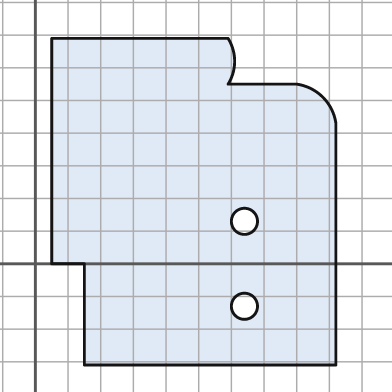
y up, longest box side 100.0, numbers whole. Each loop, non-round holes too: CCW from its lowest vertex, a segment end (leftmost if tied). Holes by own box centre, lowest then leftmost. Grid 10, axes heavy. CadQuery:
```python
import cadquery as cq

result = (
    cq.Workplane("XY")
    .moveTo(15.0, -31.0)
    .lineTo(92.0, -31.0)
    .lineTo(92.0, 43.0)
    .threePointArc((88.0, 51.0), (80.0, 55.0))
    .lineTo(59.0, 55.0)
    .threePointArc((61.0, 62.0), (59.0, 69.0))
    .lineTo(5.0, 69.0)
    .lineTo(5.0, 0.0)
    .lineTo(15.0, 0.0)
    .close()
    .moveTo(64.0, -13.0)
    .circle(4.0)
    .moveTo(64.0, 13.0)
    .circle(4.0)
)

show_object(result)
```